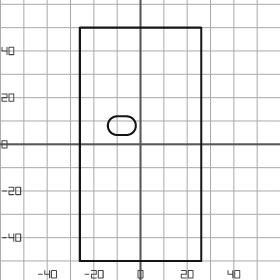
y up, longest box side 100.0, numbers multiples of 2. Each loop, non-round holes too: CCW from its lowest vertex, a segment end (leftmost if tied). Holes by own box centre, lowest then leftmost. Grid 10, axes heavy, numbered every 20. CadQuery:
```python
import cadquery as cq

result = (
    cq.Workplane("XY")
    .moveTo(-26.0, -50.0)
    .lineTo(26.0, -50.0)
    .lineTo(26.0, 50.0)
    .lineTo(-26.0, 50.0)
    .close()
    .moveTo(-10.0, 4.0)
    .lineTo(-6.0, 4.0)
    .threePointArc((-2.0, 8.0), (-6.0, 12.0))
    .lineTo(-10.0, 12.0)
    .threePointArc((-14.0, 8.0), (-10.0, 4.0))
    .close()
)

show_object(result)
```